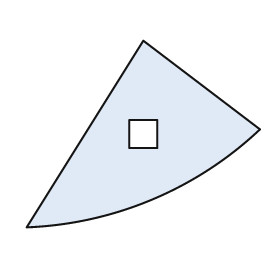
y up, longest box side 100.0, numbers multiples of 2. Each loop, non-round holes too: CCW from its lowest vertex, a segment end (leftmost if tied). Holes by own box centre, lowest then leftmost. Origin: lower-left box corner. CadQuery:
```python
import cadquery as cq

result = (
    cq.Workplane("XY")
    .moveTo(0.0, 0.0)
    .threePointArc((54.0, 12.0), (100.0, 42.0))
    .lineTo(50.0, 80.0)
    .close()
    .moveTo(44.0, 34.0)
    .lineTo(56.0, 34.0)
    .lineTo(56.0, 46.0)
    .lineTo(44.0, 46.0)
    .close()
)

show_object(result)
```